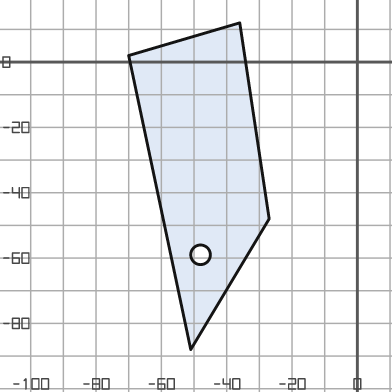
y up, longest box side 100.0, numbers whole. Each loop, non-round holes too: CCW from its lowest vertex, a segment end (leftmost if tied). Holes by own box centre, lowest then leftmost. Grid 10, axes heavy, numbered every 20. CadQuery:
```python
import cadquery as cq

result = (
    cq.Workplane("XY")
    .moveTo(-51.0, -88.0)
    .lineTo(-27.0, -48.0)
    .lineTo(-36.0, 12.0)
    .lineTo(-70.0, 2.0)
    .close()
    .moveTo(-48.0, -59.0)
    .circle(3.0)
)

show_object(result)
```